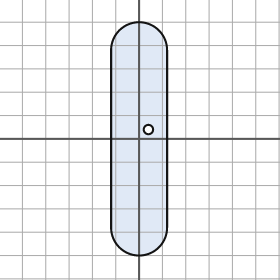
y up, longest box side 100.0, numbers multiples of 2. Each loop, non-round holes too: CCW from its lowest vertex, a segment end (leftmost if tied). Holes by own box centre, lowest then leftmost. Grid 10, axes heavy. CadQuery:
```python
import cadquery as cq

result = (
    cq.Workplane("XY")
    .moveTo(-12.0, -38.0)
    .threePointArc((0.0, -50.0), (12.0, -38.0))
    .lineTo(12.0, 38.0)
    .threePointArc((0.0, 50.0), (-12.0, 38.0))
    .close()
    .moveTo(4.0, 4.0)
    .circle(2.0)
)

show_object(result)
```